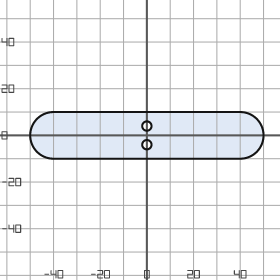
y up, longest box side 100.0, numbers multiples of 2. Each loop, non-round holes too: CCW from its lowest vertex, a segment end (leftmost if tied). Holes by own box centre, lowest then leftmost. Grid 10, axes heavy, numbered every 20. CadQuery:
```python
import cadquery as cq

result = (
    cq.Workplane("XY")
    .moveTo(-40.0, -10.0)
    .lineTo(40.0, -10.0)
    .threePointArc((50.0, 0.0), (40.0, 10.0))
    .lineTo(-40.0, 10.0)
    .threePointArc((-50.0, 0.0), (-40.0, -10.0))
    .close()
    .moveTo(0.0, -4.0)
    .circle(2.0)
    .moveTo(0.0, 4.0)
    .circle(2.0)
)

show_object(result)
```